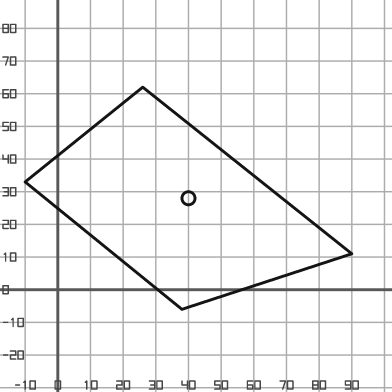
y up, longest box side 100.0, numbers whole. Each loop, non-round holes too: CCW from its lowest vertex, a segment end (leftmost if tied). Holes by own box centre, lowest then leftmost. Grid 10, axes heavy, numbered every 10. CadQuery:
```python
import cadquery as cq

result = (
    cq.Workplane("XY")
    .moveTo(38.0, -6.0)
    .lineTo(90.0, 11.0)
    .lineTo(26.0, 62.0)
    .lineTo(-10.0, 33.0)
    .close()
    .moveTo(40.0, 28.0)
    .circle(2.0)
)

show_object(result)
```